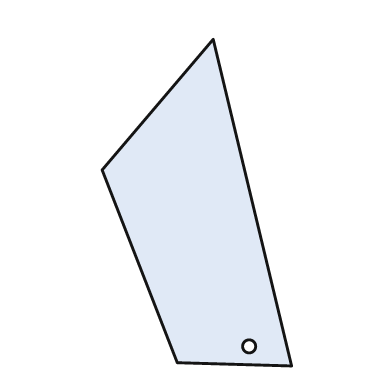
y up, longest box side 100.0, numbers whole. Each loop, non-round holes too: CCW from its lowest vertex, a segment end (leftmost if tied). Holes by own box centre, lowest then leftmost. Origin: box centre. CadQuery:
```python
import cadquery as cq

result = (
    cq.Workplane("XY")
    .moveTo(29.0, -50.0)
    .lineTo(5.0, 50.0)
    .lineTo(-29.0, 10.0)
    .lineTo(-6.0, -49.0)
    .close()
    .moveTo(16.0, -44.0)
    .circle(2.0)
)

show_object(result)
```